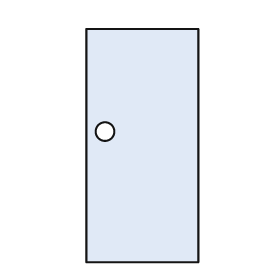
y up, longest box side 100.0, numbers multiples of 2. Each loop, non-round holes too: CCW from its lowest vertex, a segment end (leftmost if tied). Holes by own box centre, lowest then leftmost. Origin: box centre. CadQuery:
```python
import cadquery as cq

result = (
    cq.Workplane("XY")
    .moveTo(-24.0, -50.0)
    .lineTo(24.0, -50.0)
    .lineTo(24.0, 50.0)
    .lineTo(-24.0, 50.0)
    .close()
    .moveTo(-16.0, 6.0)
    .circle(4.0)
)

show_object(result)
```